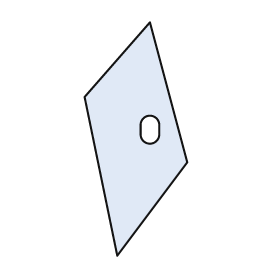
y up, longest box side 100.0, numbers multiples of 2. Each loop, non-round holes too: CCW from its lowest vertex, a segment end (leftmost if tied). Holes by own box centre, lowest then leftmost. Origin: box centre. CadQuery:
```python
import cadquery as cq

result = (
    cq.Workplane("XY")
    .moveTo(-8.0, -50.0)
    .lineTo(22.0, -10.0)
    .lineTo(6.0, 50.0)
    .lineTo(-22.0, 18.0)
    .close()
    .moveTo(2.0, 2.0)
    .threePointArc((6.0, -2.0), (10.0, 2.0))
    .lineTo(10.0, 6.0)
    .threePointArc((6.0, 10.0), (2.0, 6.0))
    .close()
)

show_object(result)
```